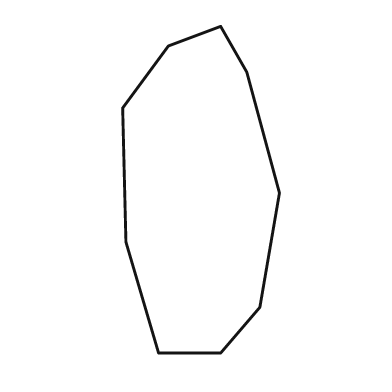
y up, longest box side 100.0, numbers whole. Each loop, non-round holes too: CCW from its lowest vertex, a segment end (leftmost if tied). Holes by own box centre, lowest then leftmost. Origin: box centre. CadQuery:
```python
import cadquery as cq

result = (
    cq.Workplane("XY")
    .moveTo(-13.0, -50.0)
    .lineTo(6.0, -50.0)
    .lineTo(18.0, -36.0)
    .lineTo(24.0, -1.0)
    .lineTo(14.0, 36.0)
    .lineTo(6.0, 50.0)
    .lineTo(-10.0, 44.0)
    .lineTo(-24.0, 25.0)
    .lineTo(-23.0, -16.0)
    .close()
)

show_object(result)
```